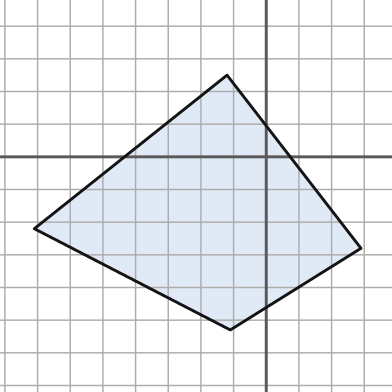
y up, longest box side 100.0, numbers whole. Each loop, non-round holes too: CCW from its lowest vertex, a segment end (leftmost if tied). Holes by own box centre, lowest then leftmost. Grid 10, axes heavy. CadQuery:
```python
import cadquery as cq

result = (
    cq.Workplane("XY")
    .moveTo(-11.0, -53.0)
    .lineTo(29.0, -28.0)
    .lineTo(-12.0, 25.0)
    .lineTo(-71.0, -22.0)
    .close()
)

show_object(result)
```